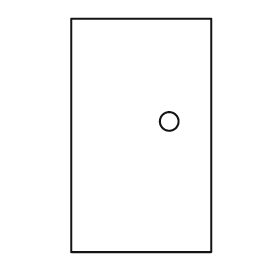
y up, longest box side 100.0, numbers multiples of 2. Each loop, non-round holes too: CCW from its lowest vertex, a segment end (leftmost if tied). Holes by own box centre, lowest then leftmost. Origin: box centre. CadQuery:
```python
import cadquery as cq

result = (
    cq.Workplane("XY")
    .moveTo(-30.0, -50.0)
    .lineTo(30.0, -50.0)
    .lineTo(30.0, 50.0)
    .lineTo(-30.0, 50.0)
    .close()
    .moveTo(12.0, 6.0)
    .circle(4.0)
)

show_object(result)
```